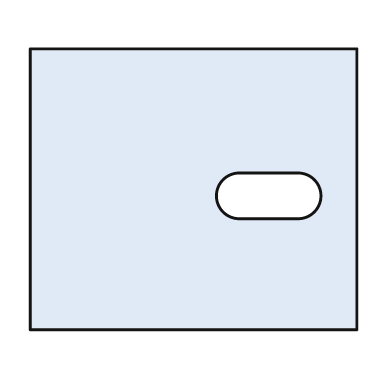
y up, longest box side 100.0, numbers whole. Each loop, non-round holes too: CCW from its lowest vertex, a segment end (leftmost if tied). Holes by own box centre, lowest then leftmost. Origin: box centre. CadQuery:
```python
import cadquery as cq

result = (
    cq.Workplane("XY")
    .moveTo(-50.0, -43.0)
    .lineTo(50.0, -43.0)
    .lineTo(50.0, 43.0)
    .lineTo(-50.0, 43.0)
    .close()
    .moveTo(14.0, -9.0)
    .lineTo(32.0, -9.0)
    .threePointArc((39.0, -2.0), (32.0, 5.0))
    .lineTo(14.0, 5.0)
    .threePointArc((7.0, -2.0), (14.0, -9.0))
    .close()
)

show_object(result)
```